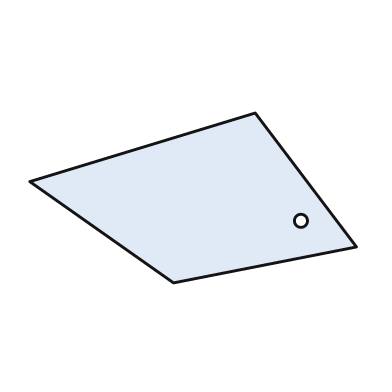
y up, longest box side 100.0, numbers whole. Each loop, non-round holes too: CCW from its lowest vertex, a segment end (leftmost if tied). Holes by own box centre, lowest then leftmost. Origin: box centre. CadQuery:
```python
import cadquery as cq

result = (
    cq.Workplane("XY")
    .moveTo(-6.0, -26.0)
    .lineTo(50.0, -15.0)
    .lineTo(19.0, 26.0)
    .lineTo(-50.0, 5.0)
    .close()
    .moveTo(33.0, -7.0)
    .circle(2.0)
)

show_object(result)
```